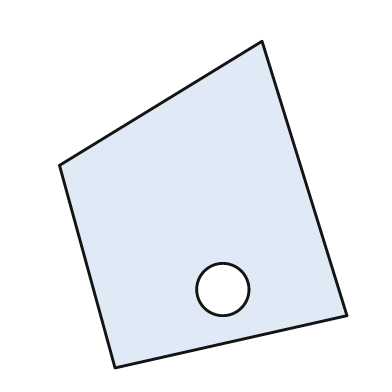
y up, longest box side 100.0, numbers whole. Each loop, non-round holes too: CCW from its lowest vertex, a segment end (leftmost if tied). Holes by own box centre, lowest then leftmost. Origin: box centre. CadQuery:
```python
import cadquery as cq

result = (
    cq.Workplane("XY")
    .moveTo(-27.0, -50.0)
    .lineTo(44.0, -34.0)
    .lineTo(18.0, 50.0)
    .lineTo(-44.0, 12.0)
    .close()
    .moveTo(6.0, -26.0)
    .circle(8.0)
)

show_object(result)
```